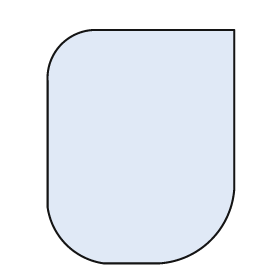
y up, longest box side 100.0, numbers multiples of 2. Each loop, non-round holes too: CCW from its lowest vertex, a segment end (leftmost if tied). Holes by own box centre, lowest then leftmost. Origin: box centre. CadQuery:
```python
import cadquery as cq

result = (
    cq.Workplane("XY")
    .moveTo(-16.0, -50.0)
    .lineTo(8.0, -50.0)
    .threePointArc((30.0, -40.0), (40.0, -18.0))
    .lineTo(40.0, 50.0)
    .lineTo(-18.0, 50.0)
    .threePointArc((-34.0, 44.0), (-40.0, 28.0))
    .lineTo(-40.0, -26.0)
    .threePointArc((-32.0, -42.0), (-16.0, -50.0))
    .close()
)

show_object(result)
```